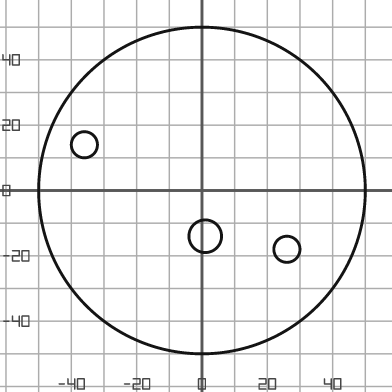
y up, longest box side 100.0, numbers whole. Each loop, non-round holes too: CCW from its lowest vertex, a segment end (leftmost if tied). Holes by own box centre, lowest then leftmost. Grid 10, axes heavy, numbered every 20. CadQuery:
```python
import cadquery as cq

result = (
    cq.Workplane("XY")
    .moveTo(0.0, 0.0)
    .circle(50.0)
    .moveTo(26.0, -18.0)
    .circle(4.0)
    .moveTo(1.0, -14.0)
    .circle(5.0)
    .moveTo(-36.0, 14.0)
    .circle(4.0)
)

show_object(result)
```